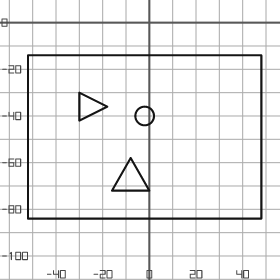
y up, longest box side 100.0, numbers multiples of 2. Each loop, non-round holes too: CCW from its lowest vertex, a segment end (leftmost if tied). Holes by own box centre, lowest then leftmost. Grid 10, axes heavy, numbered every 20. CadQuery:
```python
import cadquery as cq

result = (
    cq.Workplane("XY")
    .moveTo(-52.0, -84.0)
    .lineTo(48.0, -84.0)
    .lineTo(48.0, -14.0)
    .lineTo(-52.0, -14.0)
    .close()
    .moveTo(-16.0, -72.0)
    .lineTo(0.0, -72.0)
    .lineTo(-8.0, -58.0)
    .close()
    .moveTo(-2.0, -40.0)
    .circle(4.0)
    .moveTo(-30.0, -42.0)
    .lineTo(-18.0, -36.0)
    .lineTo(-30.0, -30.0)
    .close()
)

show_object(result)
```